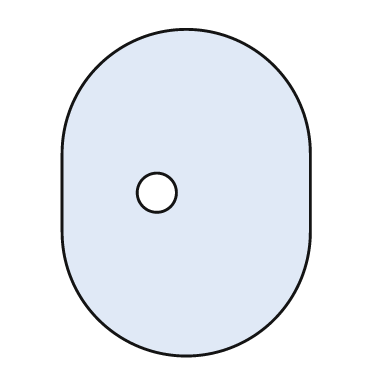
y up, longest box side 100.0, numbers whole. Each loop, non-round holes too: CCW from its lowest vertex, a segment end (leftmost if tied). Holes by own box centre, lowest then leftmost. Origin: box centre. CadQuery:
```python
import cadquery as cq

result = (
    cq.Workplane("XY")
    .moveTo(-38.0, -12.0)
    .threePointArc((0.0, -50.0), (38.0, -12.0))
    .lineTo(38.0, 12.0)
    .threePointArc((0.0, 50.0), (-38.0, 12.0))
    .close()
    .moveTo(-9.0, 0.0)
    .circle(6.0)
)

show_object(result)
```